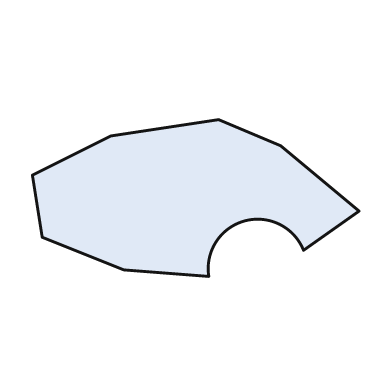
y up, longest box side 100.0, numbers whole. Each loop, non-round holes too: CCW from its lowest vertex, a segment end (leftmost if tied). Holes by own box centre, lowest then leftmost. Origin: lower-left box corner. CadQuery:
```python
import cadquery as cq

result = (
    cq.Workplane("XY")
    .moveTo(54.0, 0.0)
    .threePointArc((65.0, 17.0), (83.0, 8.0))
    .lineTo(100.0, 20.0)
    .lineTo(76.0, 40.0)
    .lineTo(57.0, 48.0)
    .lineTo(24.0, 43.0)
    .lineTo(0.0, 31.0)
    .lineTo(3.0, 12.0)
    .lineTo(28.0, 2.0)
    .close()
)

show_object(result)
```